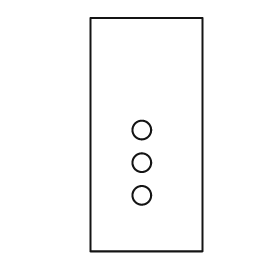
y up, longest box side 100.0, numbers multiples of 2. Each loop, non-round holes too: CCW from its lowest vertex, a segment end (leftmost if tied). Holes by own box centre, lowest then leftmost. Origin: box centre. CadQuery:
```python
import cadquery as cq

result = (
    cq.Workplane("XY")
    .moveTo(-24.0, -50.0)
    .lineTo(24.0, -50.0)
    .lineTo(24.0, 50.0)
    .lineTo(-24.0, 50.0)
    .close()
    .moveTo(-2.0, -26.0)
    .circle(4.0)
    .moveTo(-2.0, -12.0)
    .circle(4.0)
    .moveTo(-2.0, 2.0)
    .circle(4.0)
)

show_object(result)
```